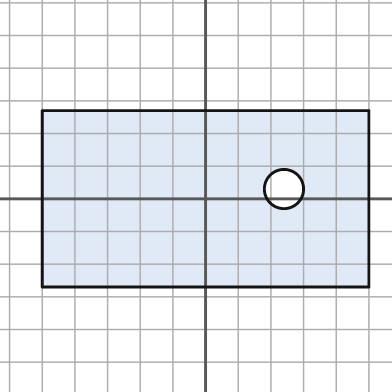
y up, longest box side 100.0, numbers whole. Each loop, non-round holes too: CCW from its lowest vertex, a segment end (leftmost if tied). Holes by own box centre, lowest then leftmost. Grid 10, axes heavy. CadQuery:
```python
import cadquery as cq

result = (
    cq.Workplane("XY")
    .moveTo(-50.0, -27.0)
    .lineTo(50.0, -27.0)
    .lineTo(50.0, 27.0)
    .lineTo(-50.0, 27.0)
    .close()
    .moveTo(24.0, 3.0)
    .circle(6.0)
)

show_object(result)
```